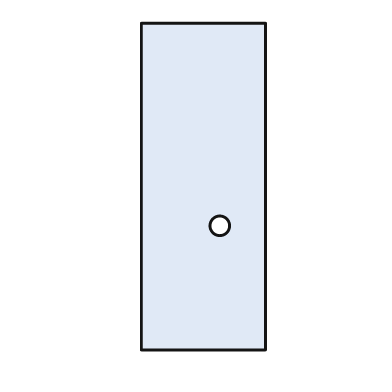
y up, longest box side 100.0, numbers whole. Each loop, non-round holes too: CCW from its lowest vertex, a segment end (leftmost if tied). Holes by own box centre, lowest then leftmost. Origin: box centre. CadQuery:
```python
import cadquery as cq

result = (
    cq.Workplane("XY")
    .moveTo(-19.0, -50.0)
    .lineTo(19.0, -50.0)
    .lineTo(19.0, 50.0)
    .lineTo(-19.0, 50.0)
    .close()
    .moveTo(5.0, -12.0)
    .circle(3.0)
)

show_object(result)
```